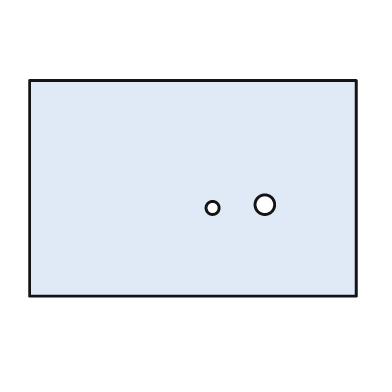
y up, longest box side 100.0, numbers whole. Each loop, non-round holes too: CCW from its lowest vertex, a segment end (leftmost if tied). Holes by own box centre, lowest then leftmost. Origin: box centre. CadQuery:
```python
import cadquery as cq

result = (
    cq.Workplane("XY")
    .moveTo(-50.0, -33.0)
    .lineTo(50.0, -33.0)
    .lineTo(50.0, 33.0)
    .lineTo(-50.0, 33.0)
    .close()
    .moveTo(6.0, -6.0)
    .circle(2.0)
    .moveTo(22.0, -5.0)
    .circle(3.0)
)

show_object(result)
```